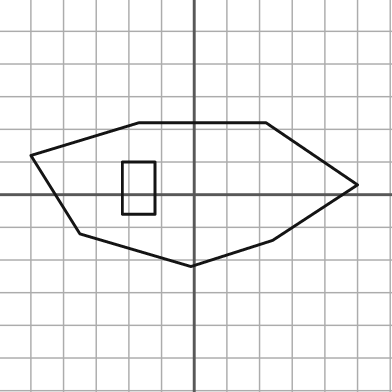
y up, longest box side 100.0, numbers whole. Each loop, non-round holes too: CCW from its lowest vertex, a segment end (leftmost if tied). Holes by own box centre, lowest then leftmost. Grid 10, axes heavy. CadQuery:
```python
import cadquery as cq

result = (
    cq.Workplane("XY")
    .moveTo(-1.0, -22.0)
    .lineTo(24.0, -14.0)
    .lineTo(50.0, 3.0)
    .lineTo(22.0, 22.0)
    .lineTo(-17.0, 22.0)
    .lineTo(-50.0, 12.0)
    .lineTo(-35.0, -12.0)
    .close()
    .moveTo(-22.0, -6.0)
    .lineTo(-12.0, -6.0)
    .lineTo(-12.0, 10.0)
    .lineTo(-22.0, 10.0)
    .close()
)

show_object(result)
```